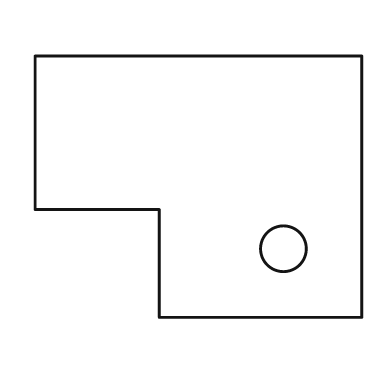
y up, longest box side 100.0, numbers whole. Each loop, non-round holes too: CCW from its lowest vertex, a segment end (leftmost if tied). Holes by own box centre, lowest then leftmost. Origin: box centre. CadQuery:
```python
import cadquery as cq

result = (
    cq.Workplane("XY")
    .moveTo(-12.0, -40.0)
    .lineTo(50.0, -40.0)
    .lineTo(50.0, 40.0)
    .lineTo(-50.0, 40.0)
    .lineTo(-50.0, -7.0)
    .lineTo(-12.0, -7.0)
    .close()
    .moveTo(26.0, -19.0)
    .circle(7.0)
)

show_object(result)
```